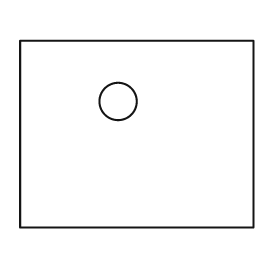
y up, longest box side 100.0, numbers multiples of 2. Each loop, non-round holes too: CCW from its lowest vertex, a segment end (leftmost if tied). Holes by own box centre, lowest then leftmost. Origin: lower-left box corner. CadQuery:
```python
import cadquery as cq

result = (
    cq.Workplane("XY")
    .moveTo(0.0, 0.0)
    .lineTo(100.0, 0.0)
    .lineTo(100.0, 80.0)
    .lineTo(0.0, 80.0)
    .close()
    .moveTo(42.0, 54.0)
    .circle(8.0)
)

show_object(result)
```